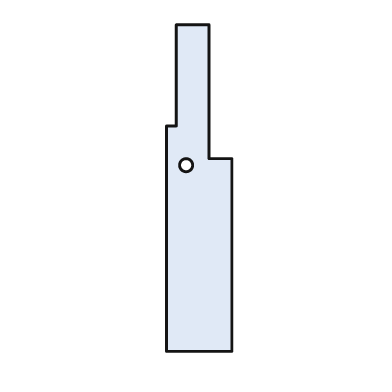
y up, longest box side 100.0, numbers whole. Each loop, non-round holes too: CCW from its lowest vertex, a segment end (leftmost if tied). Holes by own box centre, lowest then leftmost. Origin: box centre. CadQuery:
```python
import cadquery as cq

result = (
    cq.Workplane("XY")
    .moveTo(-10.0, -50.0)
    .lineTo(10.0, -50.0)
    .lineTo(10.0, 9.0)
    .lineTo(3.0, 9.0)
    .lineTo(3.0, 50.0)
    .lineTo(-7.0, 50.0)
    .lineTo(-7.0, 19.0)
    .lineTo(-10.0, 19.0)
    .close()
    .moveTo(-4.0, 7.0)
    .circle(2.0)
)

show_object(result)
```